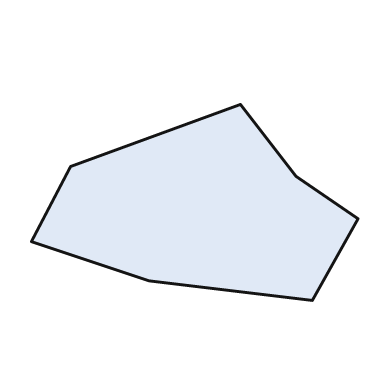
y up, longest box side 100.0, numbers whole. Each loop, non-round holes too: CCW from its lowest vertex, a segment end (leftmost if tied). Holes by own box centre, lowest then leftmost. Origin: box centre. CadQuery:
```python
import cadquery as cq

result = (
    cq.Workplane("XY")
    .moveTo(36.0, -30.0)
    .lineTo(50.0, -5.0)
    .lineTo(31.0, 8.0)
    .lineTo(14.0, 30.0)
    .lineTo(-38.0, 11.0)
    .lineTo(-50.0, -12.0)
    .lineTo(-14.0, -24.0)
    .close()
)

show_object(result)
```